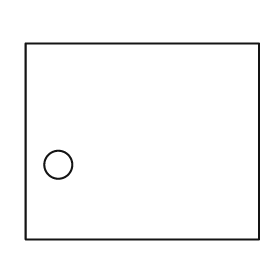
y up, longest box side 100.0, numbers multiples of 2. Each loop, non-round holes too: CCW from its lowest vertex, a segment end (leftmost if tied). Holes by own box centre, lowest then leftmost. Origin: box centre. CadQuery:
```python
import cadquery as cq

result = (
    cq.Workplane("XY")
    .moveTo(-50.0, -42.0)
    .lineTo(50.0, -42.0)
    .lineTo(50.0, 42.0)
    .lineTo(-50.0, 42.0)
    .close()
    .moveTo(-36.0, -10.0)
    .circle(6.0)
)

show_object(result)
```